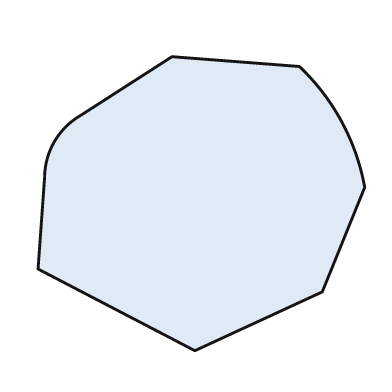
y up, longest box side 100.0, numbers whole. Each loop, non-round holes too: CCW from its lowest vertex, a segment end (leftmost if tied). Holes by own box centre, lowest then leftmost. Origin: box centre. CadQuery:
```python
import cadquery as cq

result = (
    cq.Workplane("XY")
    .moveTo(-2.0, -45.0)
    .lineTo(37.0, -27.0)
    .lineTo(50.0, 5.0)
    .threePointArc((43.0, 25.0), (30.0, 42.0))
    .lineTo(-9.0, 45.0)
    .lineTo(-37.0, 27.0)
    .threePointArc((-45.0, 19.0), (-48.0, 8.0))
    .lineTo(-50.0, -20.0)
    .close()
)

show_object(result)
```